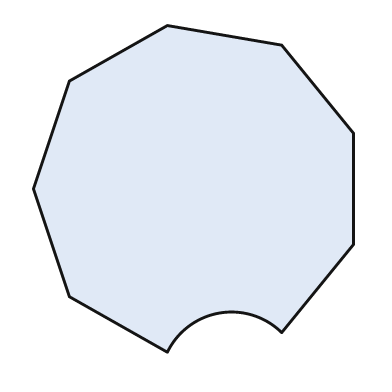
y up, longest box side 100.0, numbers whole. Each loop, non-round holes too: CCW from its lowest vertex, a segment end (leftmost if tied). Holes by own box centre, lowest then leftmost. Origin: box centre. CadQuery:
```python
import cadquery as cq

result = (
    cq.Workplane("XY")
    .moveTo(-8.0, -50.0)
    .threePointArc((8.0, -38.0), (27.0, -44.0))
    .lineTo(49.0, -17.0)
    .lineTo(49.0, 17.0)
    .lineTo(27.0, 44.0)
    .lineTo(-8.0, 50.0)
    .lineTo(-38.0, 33.0)
    .lineTo(-49.0, 0.0)
    .lineTo(-38.0, -33.0)
    .close()
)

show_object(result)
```